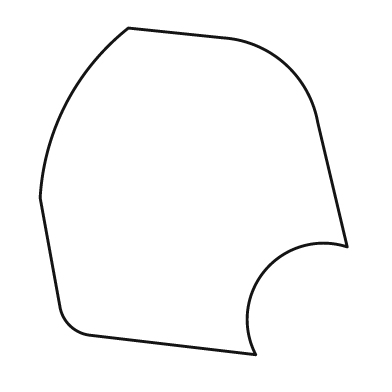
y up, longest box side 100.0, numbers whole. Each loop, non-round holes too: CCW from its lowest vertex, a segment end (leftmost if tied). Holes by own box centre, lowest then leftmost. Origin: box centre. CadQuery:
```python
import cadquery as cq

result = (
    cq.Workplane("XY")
    .moveTo(19.0, -50.0)
    .threePointArc((22.0, -24.0), (47.0, -17.0))
    .lineTo(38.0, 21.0)
    .threePointArc((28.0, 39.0), (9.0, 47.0))
    .lineTo(-20.0, 50.0)
    .threePointArc((-39.0, 27.0), (-47.0, -2.0))
    .lineTo(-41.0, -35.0)
    .threePointArc((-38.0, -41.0), (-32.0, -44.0))
    .close()
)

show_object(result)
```